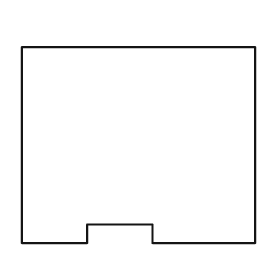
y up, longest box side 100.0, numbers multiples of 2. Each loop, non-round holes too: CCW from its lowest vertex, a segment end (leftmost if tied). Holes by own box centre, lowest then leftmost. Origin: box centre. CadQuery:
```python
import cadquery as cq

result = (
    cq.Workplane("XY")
    .moveTo(-50.0, -42.0)
    .lineTo(-22.0, -42.0)
    .lineTo(-22.0, -34.0)
    .lineTo(6.0, -34.0)
    .lineTo(6.0, -42.0)
    .lineTo(50.0, -42.0)
    .lineTo(50.0, 42.0)
    .lineTo(-50.0, 42.0)
    .close()
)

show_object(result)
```